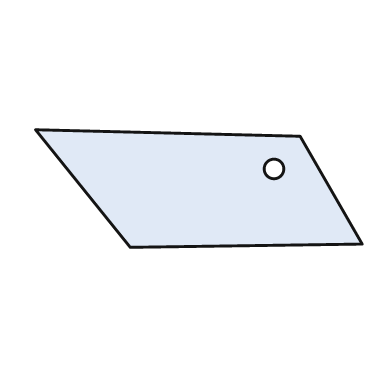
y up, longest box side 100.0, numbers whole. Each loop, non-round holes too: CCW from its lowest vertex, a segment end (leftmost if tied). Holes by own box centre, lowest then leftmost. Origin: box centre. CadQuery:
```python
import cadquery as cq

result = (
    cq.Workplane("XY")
    .moveTo(-21.0, -18.0)
    .lineTo(50.0, -17.0)
    .lineTo(31.0, 16.0)
    .lineTo(-50.0, 18.0)
    .close()
    .moveTo(23.0, 6.0)
    .circle(3.0)
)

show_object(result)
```